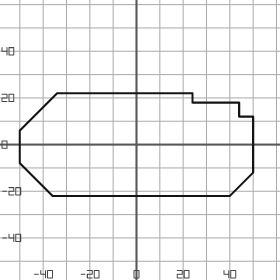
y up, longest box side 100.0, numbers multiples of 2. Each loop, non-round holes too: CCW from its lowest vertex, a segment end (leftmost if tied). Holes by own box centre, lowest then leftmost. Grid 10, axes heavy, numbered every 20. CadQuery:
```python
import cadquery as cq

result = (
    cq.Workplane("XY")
    .moveTo(-36.0, -22.0)
    .lineTo(40.0, -22.0)
    .lineTo(50.0, -12.0)
    .lineTo(50.0, 12.0)
    .lineTo(44.0, 12.0)
    .lineTo(44.0, 18.0)
    .lineTo(24.0, 18.0)
    .lineTo(24.0, 22.0)
    .lineTo(-34.0, 22.0)
    .lineTo(-50.0, 6.0)
    .lineTo(-50.0, -8.0)
    .close()
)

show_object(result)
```